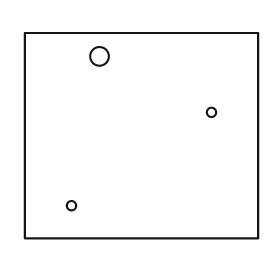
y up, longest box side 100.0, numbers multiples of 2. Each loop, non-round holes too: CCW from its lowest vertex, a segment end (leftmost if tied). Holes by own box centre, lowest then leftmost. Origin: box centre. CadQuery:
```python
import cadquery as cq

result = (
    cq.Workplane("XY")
    .moveTo(-50.0, -44.0)
    .lineTo(50.0, -44.0)
    .lineTo(50.0, 44.0)
    .lineTo(-50.0, 44.0)
    .close()
    .moveTo(-30.0, -30.0)
    .circle(2.0)
    .moveTo(30.0, 10.0)
    .circle(2.0)
    .moveTo(-18.0, 34.0)
    .circle(4.0)
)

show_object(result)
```